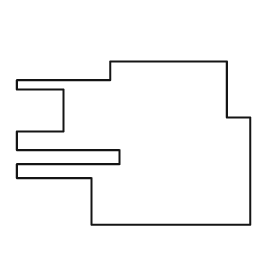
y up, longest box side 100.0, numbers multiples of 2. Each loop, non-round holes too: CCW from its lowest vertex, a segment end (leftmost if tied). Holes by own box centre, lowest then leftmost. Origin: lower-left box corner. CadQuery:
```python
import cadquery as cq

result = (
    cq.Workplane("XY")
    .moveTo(32.0, 0.0)
    .lineTo(100.0, 0.0)
    .lineTo(100.0, 46.0)
    .lineTo(90.0, 46.0)
    .lineTo(90.0, 70.0)
    .lineTo(40.0, 70.0)
    .lineTo(40.0, 62.0)
    .lineTo(0.0, 62.0)
    .lineTo(0.0, 58.0)
    .lineTo(20.0, 58.0)
    .lineTo(20.0, 40.0)
    .lineTo(0.0, 40.0)
    .lineTo(0.0, 32.0)
    .lineTo(44.0, 32.0)
    .lineTo(44.0, 26.0)
    .lineTo(0.0, 26.0)
    .lineTo(0.0, 20.0)
    .lineTo(32.0, 20.0)
    .close()
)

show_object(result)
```